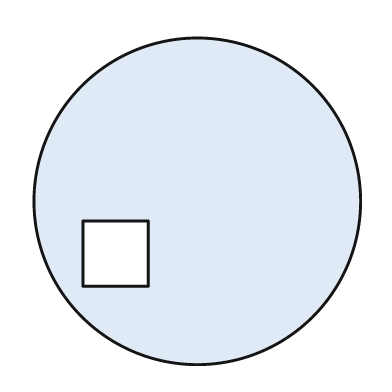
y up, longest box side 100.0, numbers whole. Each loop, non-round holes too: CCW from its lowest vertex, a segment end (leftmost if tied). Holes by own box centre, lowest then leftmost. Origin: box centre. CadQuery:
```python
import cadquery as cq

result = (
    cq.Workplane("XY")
    .moveTo(0.0, 0.0)
    .circle(50.0)
    .moveTo(-35.0, -26.0)
    .lineTo(-15.0, -26.0)
    .lineTo(-15.0, -6.0)
    .lineTo(-35.0, -6.0)
    .close()
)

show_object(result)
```